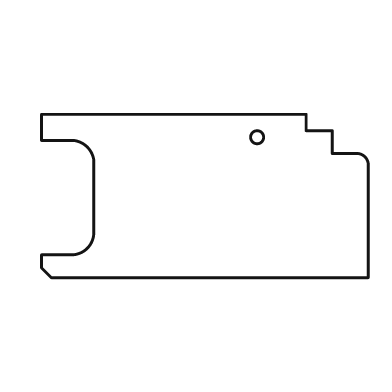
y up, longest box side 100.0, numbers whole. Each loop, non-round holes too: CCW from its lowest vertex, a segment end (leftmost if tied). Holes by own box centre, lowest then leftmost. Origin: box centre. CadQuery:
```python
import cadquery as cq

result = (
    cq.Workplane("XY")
    .moveTo(-47.0, -25.0)
    .lineTo(50.0, -25.0)
    .lineTo(50.0, 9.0)
    .threePointArc((49.0, 12.0), (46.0, 13.0))
    .lineTo(39.0, 13.0)
    .lineTo(39.0, 20.0)
    .lineTo(31.0, 20.0)
    .lineTo(31.0, 25.0)
    .lineTo(-50.0, 25.0)
    .lineTo(-50.0, 17.0)
    .lineTo(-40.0, 17.0)
    .threePointArc((-36.0, 15.0), (-34.0, 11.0))
    .lineTo(-34.0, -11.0)
    .threePointArc((-36.0, -16.0), (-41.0, -18.0))
    .lineTo(-50.0, -18.0)
    .lineTo(-50.0, -22.0)
    .close()
    .moveTo(16.0, 18.0)
    .circle(2.0)
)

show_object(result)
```